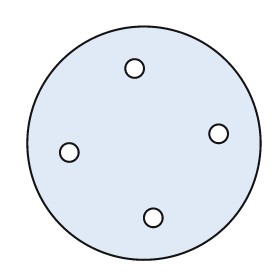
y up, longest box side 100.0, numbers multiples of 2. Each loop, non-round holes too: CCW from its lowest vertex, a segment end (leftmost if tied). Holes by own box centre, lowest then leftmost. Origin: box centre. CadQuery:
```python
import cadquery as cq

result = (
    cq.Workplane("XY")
    .moveTo(0.0, 0.0)
    .circle(50.0)
    .moveTo(4.0, -32.0)
    .circle(4.0)
    .moveTo(-32.0, -4.0)
    .circle(4.0)
    .moveTo(32.0, 4.0)
    .circle(4.0)
    .moveTo(-4.0, 32.0)
    .circle(4.0)
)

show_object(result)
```